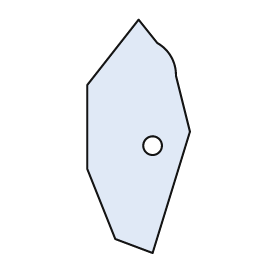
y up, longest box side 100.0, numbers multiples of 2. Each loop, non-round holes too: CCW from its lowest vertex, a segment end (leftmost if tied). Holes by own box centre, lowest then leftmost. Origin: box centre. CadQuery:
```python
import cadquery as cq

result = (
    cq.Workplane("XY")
    .moveTo(6.0, -50.0)
    .lineTo(22.0, 2.0)
    .lineTo(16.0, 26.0)
    .threePointArc((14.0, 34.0), (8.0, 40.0))
    .lineTo(0.0, 50.0)
    .lineTo(-22.0, 22.0)
    .lineTo(-22.0, -14.0)
    .lineTo(-10.0, -44.0)
    .close()
    .moveTo(6.0, -4.0)
    .circle(4.0)
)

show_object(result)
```